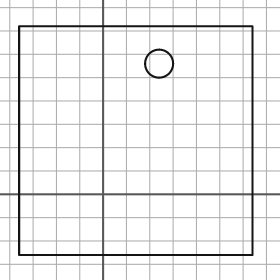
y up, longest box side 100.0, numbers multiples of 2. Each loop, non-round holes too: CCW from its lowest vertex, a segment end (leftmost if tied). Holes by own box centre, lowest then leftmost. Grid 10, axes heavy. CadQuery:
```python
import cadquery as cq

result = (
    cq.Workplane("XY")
    .moveTo(-36.0, -26.0)
    .lineTo(64.0, -26.0)
    .lineTo(64.0, 72.0)
    .lineTo(-36.0, 72.0)
    .close()
    .moveTo(24.0, 56.0)
    .circle(6.0)
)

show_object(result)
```